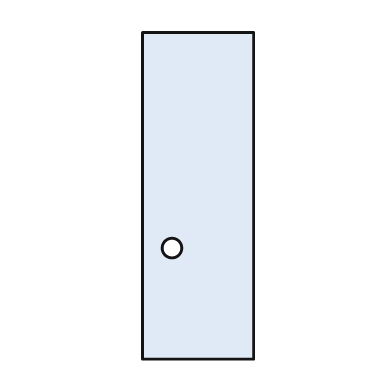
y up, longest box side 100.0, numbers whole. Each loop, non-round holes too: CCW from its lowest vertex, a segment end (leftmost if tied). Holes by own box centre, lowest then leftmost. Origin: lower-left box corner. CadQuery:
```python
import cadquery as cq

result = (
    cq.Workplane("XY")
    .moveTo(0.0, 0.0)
    .lineTo(34.0, 0.0)
    .lineTo(34.0, 100.0)
    .lineTo(0.0, 100.0)
    .close()
    .moveTo(9.0, 34.0)
    .circle(3.0)
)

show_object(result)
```